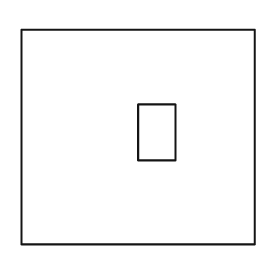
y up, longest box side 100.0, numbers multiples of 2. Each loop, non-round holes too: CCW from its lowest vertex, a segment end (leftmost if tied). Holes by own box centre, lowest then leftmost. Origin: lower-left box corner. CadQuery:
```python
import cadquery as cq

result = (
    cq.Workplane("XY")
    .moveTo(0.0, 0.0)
    .lineTo(100.0, 0.0)
    .lineTo(100.0, 92.0)
    .lineTo(0.0, 92.0)
    .close()
    .moveTo(50.0, 36.0)
    .lineTo(66.0, 36.0)
    .lineTo(66.0, 60.0)
    .lineTo(50.0, 60.0)
    .close()
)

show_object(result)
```